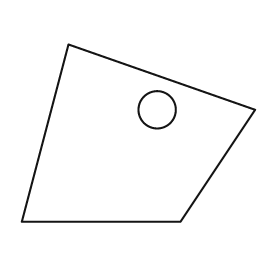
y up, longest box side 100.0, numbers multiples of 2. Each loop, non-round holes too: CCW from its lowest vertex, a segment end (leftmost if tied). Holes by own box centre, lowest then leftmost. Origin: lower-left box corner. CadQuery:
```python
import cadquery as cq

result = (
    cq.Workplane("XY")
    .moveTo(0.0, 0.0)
    .lineTo(68.0, 0.0)
    .lineTo(100.0, 48.0)
    .lineTo(20.0, 76.0)
    .close()
    .moveTo(58.0, 48.0)
    .circle(8.0)
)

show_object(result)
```